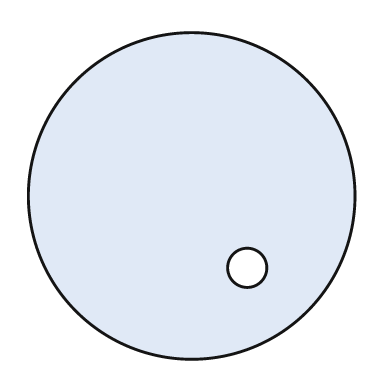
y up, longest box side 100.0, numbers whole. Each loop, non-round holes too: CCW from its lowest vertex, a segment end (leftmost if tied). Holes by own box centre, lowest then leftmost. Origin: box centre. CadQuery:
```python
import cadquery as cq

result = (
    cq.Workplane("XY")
    .moveTo(0.0, 0.0)
    .circle(50.0)
    .moveTo(17.0, -22.0)
    .circle(6.0)
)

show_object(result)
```